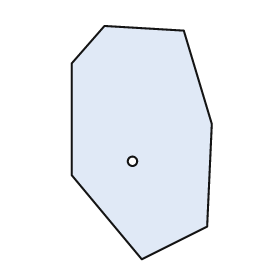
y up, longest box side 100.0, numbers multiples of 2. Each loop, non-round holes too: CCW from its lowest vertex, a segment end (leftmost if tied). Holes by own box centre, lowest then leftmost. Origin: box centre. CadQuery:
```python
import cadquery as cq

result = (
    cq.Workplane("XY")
    .moveTo(0.0, -50.0)
    .lineTo(28.0, -36.0)
    .lineTo(30.0, 8.0)
    .lineTo(18.0, 48.0)
    .lineTo(-16.0, 50.0)
    .lineTo(-30.0, 34.0)
    .lineTo(-30.0, -14.0)
    .close()
    .moveTo(-4.0, -8.0)
    .circle(2.0)
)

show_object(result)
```